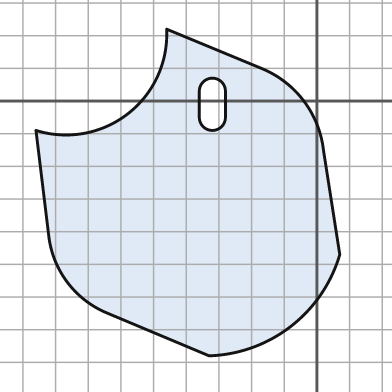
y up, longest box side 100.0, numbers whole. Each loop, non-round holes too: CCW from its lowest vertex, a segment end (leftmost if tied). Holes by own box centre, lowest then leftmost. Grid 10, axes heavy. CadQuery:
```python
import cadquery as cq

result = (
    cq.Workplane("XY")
    .moveTo(-33.0, -78.0)
    .threePointArc((-8.0, -69.0), (7.0, -47.0))
    .lineTo(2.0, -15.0)
    .threePointArc((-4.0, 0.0), (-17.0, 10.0))
    .lineTo(-46.0, 22.0)
    .threePointArc((-58.0, -4.0), (-86.0, -9.0))
    .lineTo(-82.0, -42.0)
    .threePointArc((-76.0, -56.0), (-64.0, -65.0))
    .close()
    .moveTo(-36.0, -5.0)
    .threePointArc((-32.0, -9.0), (-28.0, -5.0))
    .lineTo(-28.0, 3.0)
    .threePointArc((-32.0, 7.0), (-36.0, 3.0))
    .close()
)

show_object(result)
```